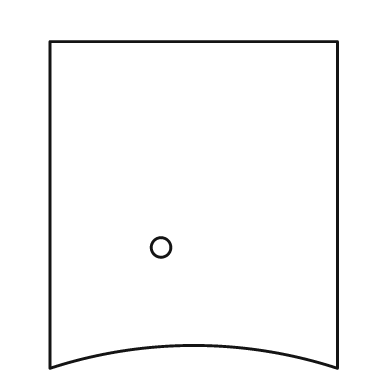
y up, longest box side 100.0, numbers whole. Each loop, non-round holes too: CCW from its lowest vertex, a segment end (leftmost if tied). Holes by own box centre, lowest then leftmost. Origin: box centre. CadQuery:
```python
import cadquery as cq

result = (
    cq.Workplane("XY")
    .moveTo(-44.0, -50.0)
    .threePointArc((0.0, -43.0), (44.0, -50.0))
    .lineTo(44.0, 50.0)
    .lineTo(-44.0, 50.0)
    .close()
    .moveTo(-10.0, -13.0)
    .circle(3.0)
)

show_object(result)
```